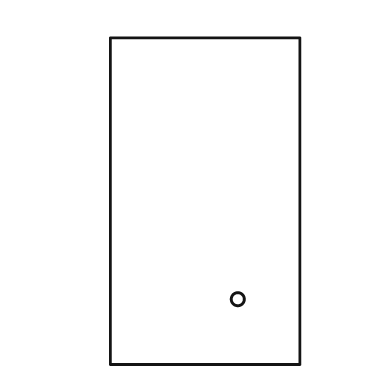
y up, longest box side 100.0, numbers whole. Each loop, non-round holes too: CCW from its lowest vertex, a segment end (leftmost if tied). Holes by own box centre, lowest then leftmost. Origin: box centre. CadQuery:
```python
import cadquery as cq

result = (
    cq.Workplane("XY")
    .moveTo(-29.0, -50.0)
    .lineTo(29.0, -50.0)
    .lineTo(29.0, 50.0)
    .lineTo(-29.0, 50.0)
    .close()
    .moveTo(10.0, -30.0)
    .circle(2.0)
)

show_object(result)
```